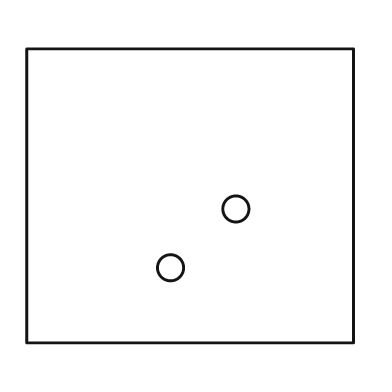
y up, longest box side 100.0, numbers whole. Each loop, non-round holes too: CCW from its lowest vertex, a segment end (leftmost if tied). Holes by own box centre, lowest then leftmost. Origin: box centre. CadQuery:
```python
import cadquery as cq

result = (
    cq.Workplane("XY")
    .moveTo(-50.0, -45.0)
    .lineTo(50.0, -45.0)
    .lineTo(50.0, 45.0)
    .lineTo(-50.0, 45.0)
    .close()
    .moveTo(-6.0, -22.0)
    .circle(4.0)
    .moveTo(14.0, -4.0)
    .circle(4.0)
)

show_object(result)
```